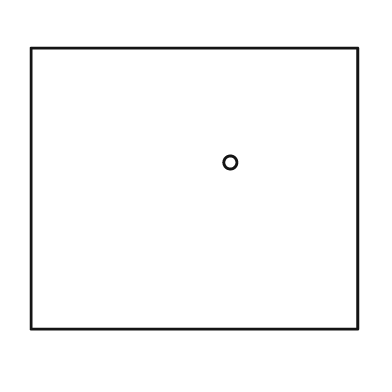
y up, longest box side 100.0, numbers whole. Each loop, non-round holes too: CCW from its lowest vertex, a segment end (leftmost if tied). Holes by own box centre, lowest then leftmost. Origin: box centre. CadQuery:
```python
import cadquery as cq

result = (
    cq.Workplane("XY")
    .moveTo(-50.0, -43.0)
    .lineTo(50.0, -43.0)
    .lineTo(50.0, 43.0)
    .lineTo(-50.0, 43.0)
    .close()
    .moveTo(11.0, 8.0)
    .circle(2.0)
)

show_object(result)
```